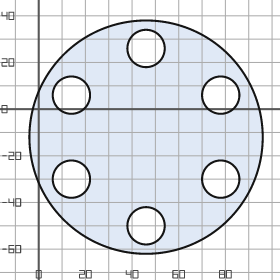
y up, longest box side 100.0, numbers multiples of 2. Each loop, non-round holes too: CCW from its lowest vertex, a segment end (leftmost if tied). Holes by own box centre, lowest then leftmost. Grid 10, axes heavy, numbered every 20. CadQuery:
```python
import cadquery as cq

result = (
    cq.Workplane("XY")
    .moveTo(46.0, -12.0)
    .circle(50.0)
    .moveTo(46.0, -50.0)
    .circle(8.0)
    .moveTo(14.0, -30.0)
    .circle(8.0)
    .moveTo(78.0, -30.0)
    .circle(8.0)
    .moveTo(14.0, 6.0)
    .circle(8.0)
    .moveTo(78.0, 6.0)
    .circle(8.0)
    .moveTo(46.0, 26.0)
    .circle(8.0)
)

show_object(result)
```